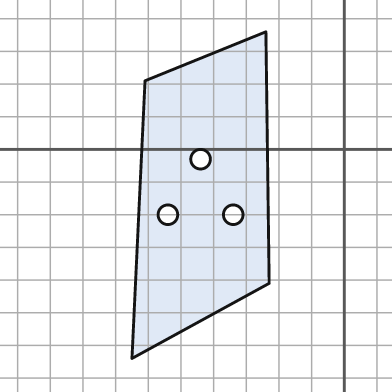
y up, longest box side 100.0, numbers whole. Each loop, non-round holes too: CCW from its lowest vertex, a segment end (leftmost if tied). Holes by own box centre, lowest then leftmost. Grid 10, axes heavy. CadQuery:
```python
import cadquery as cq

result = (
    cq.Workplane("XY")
    .moveTo(-65.0, -64.0)
    .lineTo(-23.0, -41.0)
    .lineTo(-24.0, 36.0)
    .lineTo(-61.0, 21.0)
    .close()
    .moveTo(-54.0, -20.0)
    .circle(3.0)
    .moveTo(-34.0, -20.0)
    .circle(3.0)
    .moveTo(-44.0, -3.0)
    .circle(3.0)
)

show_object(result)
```